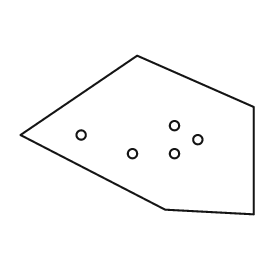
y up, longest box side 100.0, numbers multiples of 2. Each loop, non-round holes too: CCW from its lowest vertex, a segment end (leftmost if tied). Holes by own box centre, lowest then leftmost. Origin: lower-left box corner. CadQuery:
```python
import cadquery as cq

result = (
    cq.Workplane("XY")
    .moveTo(100.0, 0.0)
    .lineTo(100.0, 46.0)
    .lineTo(50.0, 68.0)
    .lineTo(0.0, 34.0)
    .lineTo(62.0, 2.0)
    .close()
    .moveTo(48.0, 26.0)
    .circle(2.0)
    .moveTo(66.0, 26.0)
    .circle(2.0)
    .moveTo(76.0, 32.0)
    .circle(2.0)
    .moveTo(26.0, 34.0)
    .circle(2.0)
    .moveTo(66.0, 38.0)
    .circle(2.0)
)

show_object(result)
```